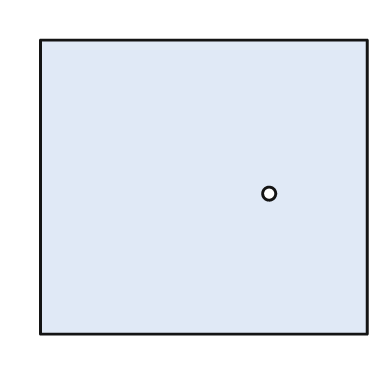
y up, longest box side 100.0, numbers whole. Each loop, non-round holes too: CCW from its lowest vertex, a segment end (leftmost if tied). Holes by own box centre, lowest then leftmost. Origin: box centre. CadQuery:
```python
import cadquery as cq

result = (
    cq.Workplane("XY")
    .moveTo(-50.0, -45.0)
    .lineTo(50.0, -45.0)
    .lineTo(50.0, 45.0)
    .lineTo(-50.0, 45.0)
    .close()
    .moveTo(20.0, -2.0)
    .circle(2.0)
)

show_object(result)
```